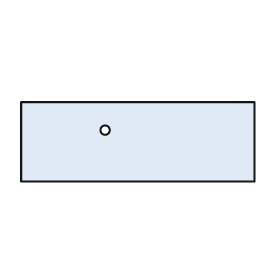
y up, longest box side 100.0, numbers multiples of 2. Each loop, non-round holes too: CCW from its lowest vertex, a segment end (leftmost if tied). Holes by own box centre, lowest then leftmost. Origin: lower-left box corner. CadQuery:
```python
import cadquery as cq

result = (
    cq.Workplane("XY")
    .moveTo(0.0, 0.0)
    .lineTo(100.0, 0.0)
    .lineTo(100.0, 34.0)
    .lineTo(0.0, 34.0)
    .close()
    .moveTo(36.0, 22.0)
    .circle(2.0)
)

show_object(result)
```